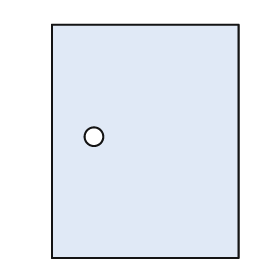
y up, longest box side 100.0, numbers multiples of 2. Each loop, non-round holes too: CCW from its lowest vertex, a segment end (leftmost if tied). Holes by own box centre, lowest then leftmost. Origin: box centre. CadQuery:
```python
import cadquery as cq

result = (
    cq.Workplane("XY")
    .moveTo(-40.0, -50.0)
    .lineTo(40.0, -50.0)
    .lineTo(40.0, 50.0)
    .lineTo(-40.0, 50.0)
    .close()
    .moveTo(-22.0, 2.0)
    .circle(4.0)
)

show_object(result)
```